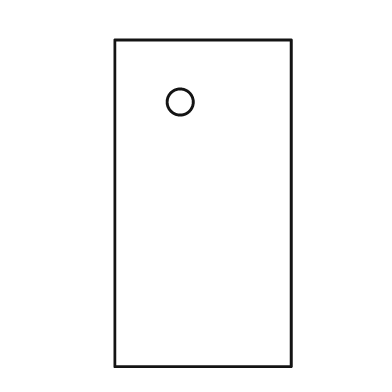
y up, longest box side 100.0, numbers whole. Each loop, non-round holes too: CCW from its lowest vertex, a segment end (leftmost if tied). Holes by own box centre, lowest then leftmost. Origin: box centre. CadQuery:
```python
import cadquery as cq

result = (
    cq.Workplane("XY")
    .moveTo(-27.0, -50.0)
    .lineTo(27.0, -50.0)
    .lineTo(27.0, 50.0)
    .lineTo(-27.0, 50.0)
    .close()
    .moveTo(-7.0, 31.0)
    .circle(4.0)
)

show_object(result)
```